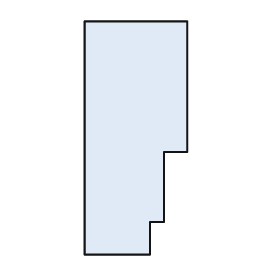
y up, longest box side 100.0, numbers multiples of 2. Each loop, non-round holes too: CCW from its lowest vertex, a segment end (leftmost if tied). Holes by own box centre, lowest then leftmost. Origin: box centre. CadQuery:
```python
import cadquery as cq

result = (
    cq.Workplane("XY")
    .moveTo(-22.0, -50.0)
    .lineTo(6.0, -50.0)
    .lineTo(6.0, -36.0)
    .lineTo(12.0, -36.0)
    .lineTo(12.0, -6.0)
    .lineTo(22.0, -6.0)
    .lineTo(22.0, 50.0)
    .lineTo(-22.0, 50.0)
    .close()
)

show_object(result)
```